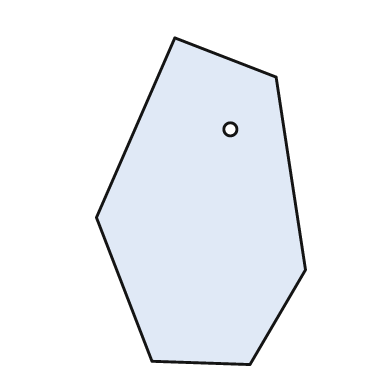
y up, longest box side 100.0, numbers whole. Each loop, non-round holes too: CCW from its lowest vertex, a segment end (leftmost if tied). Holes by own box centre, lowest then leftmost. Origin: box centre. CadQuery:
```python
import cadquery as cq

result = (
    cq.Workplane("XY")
    .moveTo(15.0, -50.0)
    .lineTo(32.0, -21.0)
    .lineTo(23.0, 38.0)
    .lineTo(-8.0, 50.0)
    .lineTo(-32.0, -5.0)
    .lineTo(-15.0, -49.0)
    .close()
    .moveTo(9.0, 22.0)
    .circle(2.0)
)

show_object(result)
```